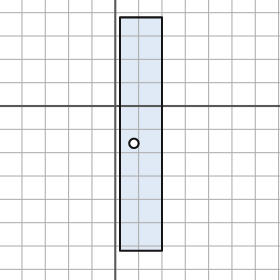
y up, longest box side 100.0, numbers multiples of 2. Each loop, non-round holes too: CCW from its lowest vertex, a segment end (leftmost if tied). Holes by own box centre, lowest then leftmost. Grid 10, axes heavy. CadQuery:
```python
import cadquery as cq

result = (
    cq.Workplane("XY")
    .moveTo(2.0, -62.0)
    .lineTo(20.0, -62.0)
    .lineTo(20.0, 38.0)
    .lineTo(2.0, 38.0)
    .close()
    .moveTo(8.0, -16.0)
    .circle(2.0)
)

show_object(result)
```